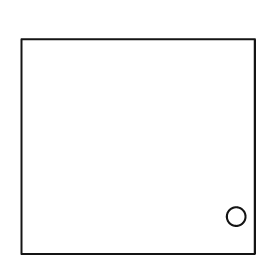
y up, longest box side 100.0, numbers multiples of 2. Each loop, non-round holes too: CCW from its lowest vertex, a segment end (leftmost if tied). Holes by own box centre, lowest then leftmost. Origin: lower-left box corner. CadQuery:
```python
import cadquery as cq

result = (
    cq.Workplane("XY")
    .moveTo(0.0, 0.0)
    .lineTo(100.0, 0.0)
    .lineTo(100.0, 92.0)
    .lineTo(0.0, 92.0)
    .close()
    .moveTo(92.0, 16.0)
    .circle(4.0)
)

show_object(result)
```